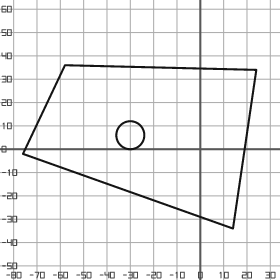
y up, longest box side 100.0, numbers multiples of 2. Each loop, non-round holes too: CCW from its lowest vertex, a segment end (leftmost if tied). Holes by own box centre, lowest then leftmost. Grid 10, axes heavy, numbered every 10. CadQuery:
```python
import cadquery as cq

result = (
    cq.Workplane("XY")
    .moveTo(14.0, -34.0)
    .lineTo(24.0, 34.0)
    .lineTo(-58.0, 36.0)
    .lineTo(-76.0, -2.0)
    .close()
    .moveTo(-30.0, 6.0)
    .circle(6.0)
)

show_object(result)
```